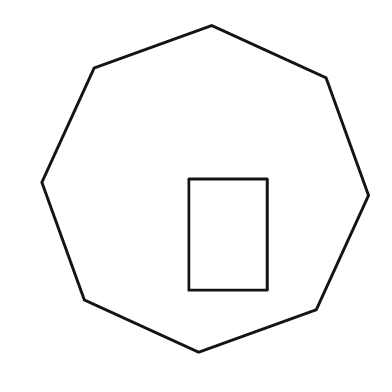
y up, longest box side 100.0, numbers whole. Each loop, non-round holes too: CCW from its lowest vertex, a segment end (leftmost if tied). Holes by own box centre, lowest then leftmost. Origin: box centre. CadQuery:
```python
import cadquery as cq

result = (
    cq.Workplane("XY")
    .moveTo(-2.0, -50.0)
    .lineTo(34.0, -37.0)
    .lineTo(50.0, -2.0)
    .lineTo(37.0, 34.0)
    .lineTo(2.0, 50.0)
    .lineTo(-34.0, 37.0)
    .lineTo(-50.0, 2.0)
    .lineTo(-37.0, -34.0)
    .close()
    .moveTo(-5.0, -31.0)
    .lineTo(19.0, -31.0)
    .lineTo(19.0, 3.0)
    .lineTo(-5.0, 3.0)
    .close()
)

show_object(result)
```